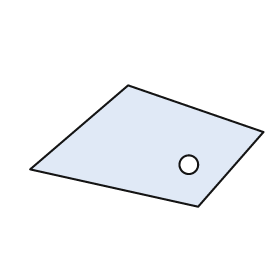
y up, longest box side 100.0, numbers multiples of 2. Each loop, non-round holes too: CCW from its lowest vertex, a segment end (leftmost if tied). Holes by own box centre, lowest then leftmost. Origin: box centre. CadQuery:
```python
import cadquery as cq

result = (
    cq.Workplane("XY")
    .moveTo(22.0, -26.0)
    .lineTo(50.0, 6.0)
    .lineTo(-8.0, 26.0)
    .lineTo(-50.0, -10.0)
    .close()
    .moveTo(18.0, -8.0)
    .circle(4.0)
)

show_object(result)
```